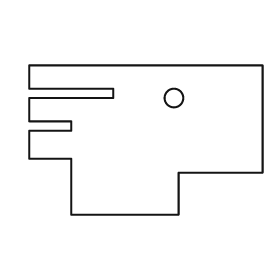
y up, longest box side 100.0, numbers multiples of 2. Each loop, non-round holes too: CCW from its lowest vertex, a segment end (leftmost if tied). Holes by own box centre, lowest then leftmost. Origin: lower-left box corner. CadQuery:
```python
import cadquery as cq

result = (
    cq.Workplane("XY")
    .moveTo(18.0, 0.0)
    .lineTo(64.0, 0.0)
    .lineTo(64.0, 18.0)
    .lineTo(100.0, 18.0)
    .lineTo(100.0, 64.0)
    .lineTo(0.0, 64.0)
    .lineTo(0.0, 54.0)
    .lineTo(36.0, 54.0)
    .lineTo(36.0, 50.0)
    .lineTo(0.0, 50.0)
    .lineTo(0.0, 40.0)
    .lineTo(18.0, 40.0)
    .lineTo(18.0, 36.0)
    .lineTo(0.0, 36.0)
    .lineTo(0.0, 24.0)
    .lineTo(18.0, 24.0)
    .close()
    .moveTo(62.0, 50.0)
    .circle(4.0)
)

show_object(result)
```